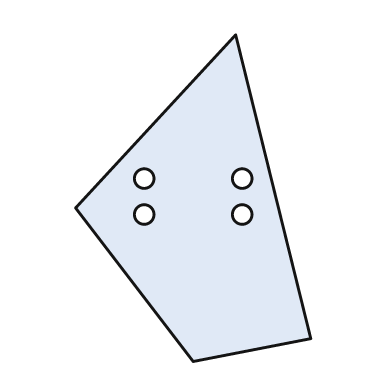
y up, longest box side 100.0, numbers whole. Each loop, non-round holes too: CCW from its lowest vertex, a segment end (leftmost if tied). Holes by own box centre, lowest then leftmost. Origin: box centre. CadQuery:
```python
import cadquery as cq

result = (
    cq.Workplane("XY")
    .moveTo(0.0, -50.0)
    .lineTo(36.0, -43.0)
    .lineTo(13.0, 50.0)
    .lineTo(-36.0, -3.0)
    .close()
    .moveTo(-15.0, -5.0)
    .circle(3.0)
    .moveTo(15.0, -5.0)
    .circle(3.0)
    .moveTo(-15.0, 6.0)
    .circle(3.0)
    .moveTo(15.0, 6.0)
    .circle(3.0)
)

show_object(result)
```